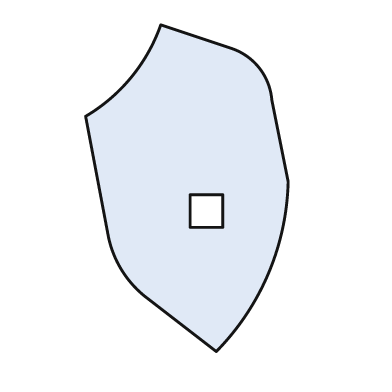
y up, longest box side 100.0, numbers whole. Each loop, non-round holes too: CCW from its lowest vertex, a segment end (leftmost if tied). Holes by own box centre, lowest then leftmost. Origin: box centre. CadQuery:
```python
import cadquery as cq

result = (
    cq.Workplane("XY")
    .moveTo(9.0, -50.0)
    .threePointArc((25.0, -26.0), (31.0, 2.0))
    .lineTo(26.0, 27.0)
    .threePointArc((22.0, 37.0), (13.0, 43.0))
    .lineTo(-8.0, 50.0)
    .threePointArc((-17.0, 34.0), (-31.0, 22.0))
    .lineTo(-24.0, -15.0)
    .threePointArc((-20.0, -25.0), (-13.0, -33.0))
    .close()
    .moveTo(1.0, -12.0)
    .lineTo(11.0, -12.0)
    .lineTo(11.0, -2.0)
    .lineTo(1.0, -2.0)
    .close()
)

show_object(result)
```